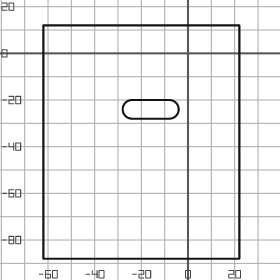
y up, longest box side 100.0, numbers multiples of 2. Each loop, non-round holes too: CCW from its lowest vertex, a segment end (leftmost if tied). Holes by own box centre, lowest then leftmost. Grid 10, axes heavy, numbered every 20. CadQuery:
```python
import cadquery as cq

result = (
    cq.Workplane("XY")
    .moveTo(-62.0, -88.0)
    .lineTo(22.0, -88.0)
    .lineTo(22.0, 12.0)
    .lineTo(-62.0, 12.0)
    .close()
    .moveTo(-24.0, -28.0)
    .lineTo(-8.0, -28.0)
    .threePointArc((-4.0, -24.0), (-8.0, -20.0))
    .lineTo(-24.0, -20.0)
    .threePointArc((-28.0, -24.0), (-24.0, -28.0))
    .close()
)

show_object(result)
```